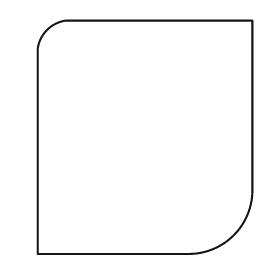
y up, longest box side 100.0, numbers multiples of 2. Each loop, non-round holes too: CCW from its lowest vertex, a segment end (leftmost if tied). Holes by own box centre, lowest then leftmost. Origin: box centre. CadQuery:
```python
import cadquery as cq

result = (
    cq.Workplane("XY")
    .moveTo(-46.0, -50.0)
    .lineTo(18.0, -50.0)
    .threePointArc((38.0, -42.0), (46.0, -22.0))
    .lineTo(46.0, 50.0)
    .lineTo(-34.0, 50.0)
    .threePointArc((-42.0, 46.0), (-46.0, 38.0))
    .close()
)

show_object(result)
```